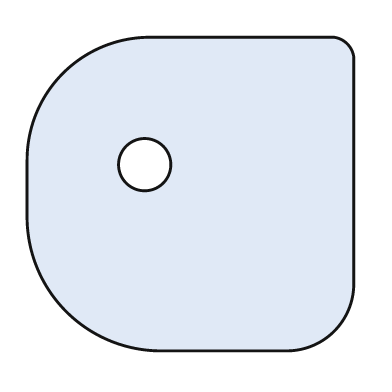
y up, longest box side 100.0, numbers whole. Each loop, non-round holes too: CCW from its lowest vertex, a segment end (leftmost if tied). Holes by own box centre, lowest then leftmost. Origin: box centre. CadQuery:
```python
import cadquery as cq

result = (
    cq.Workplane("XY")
    .moveTo(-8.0, -48.0)
    .lineTo(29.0, -48.0)
    .threePointArc((44.0, -42.0), (50.0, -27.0))
    .lineTo(50.0, 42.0)
    .threePointArc((48.0, 46.0), (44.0, 48.0))
    .lineTo(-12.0, 48.0)
    .threePointArc((-39.0, 37.0), (-50.0, 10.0))
    .lineTo(-50.0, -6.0)
    .threePointArc((-38.0, -36.0), (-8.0, -48.0))
    .close()
    .moveTo(-14.0, 9.0)
    .circle(8.0)
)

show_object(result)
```